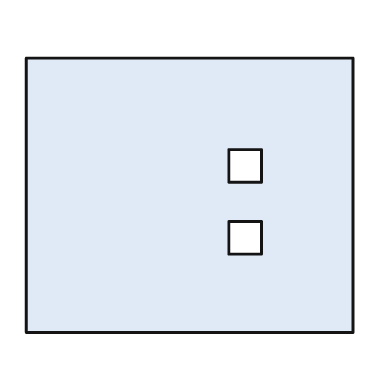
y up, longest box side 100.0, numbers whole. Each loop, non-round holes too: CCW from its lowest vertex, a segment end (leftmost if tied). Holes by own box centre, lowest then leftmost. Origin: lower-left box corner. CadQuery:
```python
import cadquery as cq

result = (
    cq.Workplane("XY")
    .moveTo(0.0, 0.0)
    .lineTo(100.0, 0.0)
    .lineTo(100.0, 84.0)
    .lineTo(0.0, 84.0)
    .close()
    .moveTo(62.0, 24.0)
    .lineTo(72.0, 24.0)
    .lineTo(72.0, 34.0)
    .lineTo(62.0, 34.0)
    .close()
    .moveTo(62.0, 46.0)
    .lineTo(72.0, 46.0)
    .lineTo(72.0, 56.0)
    .lineTo(62.0, 56.0)
    .close()
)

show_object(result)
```